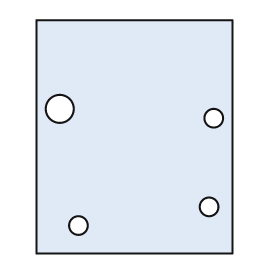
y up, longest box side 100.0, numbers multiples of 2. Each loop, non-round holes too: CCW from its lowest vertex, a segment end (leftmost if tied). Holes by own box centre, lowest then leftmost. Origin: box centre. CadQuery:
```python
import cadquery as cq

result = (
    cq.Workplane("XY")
    .moveTo(-42.0, -50.0)
    .lineTo(42.0, -50.0)
    .lineTo(42.0, 50.0)
    .lineTo(-42.0, 50.0)
    .close()
    .moveTo(-24.0, -38.0)
    .circle(4.0)
    .moveTo(32.0, -30.0)
    .circle(4.0)
    .moveTo(34.0, 8.0)
    .circle(4.0)
    .moveTo(-32.0, 12.0)
    .circle(6.0)
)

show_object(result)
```